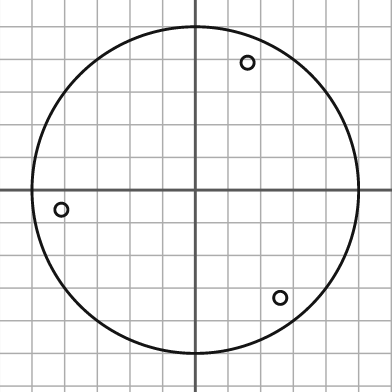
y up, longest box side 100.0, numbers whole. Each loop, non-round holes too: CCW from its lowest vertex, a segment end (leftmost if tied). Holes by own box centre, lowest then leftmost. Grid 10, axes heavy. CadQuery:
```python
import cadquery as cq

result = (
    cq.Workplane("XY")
    .moveTo(0.0, 0.0)
    .circle(50.0)
    .moveTo(26.0, -33.0)
    .circle(2.0)
    .moveTo(-41.0, -6.0)
    .circle(2.0)
    .moveTo(16.0, 39.0)
    .circle(2.0)
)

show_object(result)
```